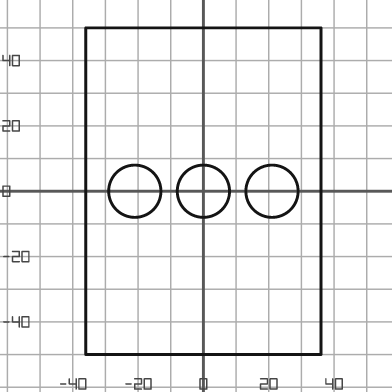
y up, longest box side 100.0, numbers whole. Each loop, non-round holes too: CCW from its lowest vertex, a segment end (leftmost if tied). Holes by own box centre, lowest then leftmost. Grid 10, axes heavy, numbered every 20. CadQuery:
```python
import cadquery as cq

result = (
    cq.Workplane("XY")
    .moveTo(-36.0, -50.0)
    .lineTo(36.0, -50.0)
    .lineTo(36.0, 50.0)
    .lineTo(-36.0, 50.0)
    .close()
    .moveTo(-21.0, 0.0)
    .circle(8.0)
    .moveTo(0.0, 0.0)
    .circle(8.0)
    .moveTo(21.0, 0.0)
    .circle(8.0)
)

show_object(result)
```